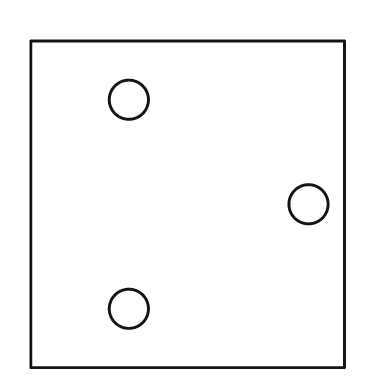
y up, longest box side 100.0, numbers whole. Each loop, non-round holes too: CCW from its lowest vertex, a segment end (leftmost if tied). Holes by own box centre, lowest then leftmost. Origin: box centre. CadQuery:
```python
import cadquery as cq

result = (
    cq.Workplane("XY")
    .moveTo(-48.0, -50.0)
    .lineTo(48.0, -50.0)
    .lineTo(48.0, 50.0)
    .lineTo(-48.0, 50.0)
    .close()
    .moveTo(-18.0, -32.0)
    .circle(6.0)
    .moveTo(37.0, 0.0)
    .circle(6.0)
    .moveTo(-18.0, 32.0)
    .circle(6.0)
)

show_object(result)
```